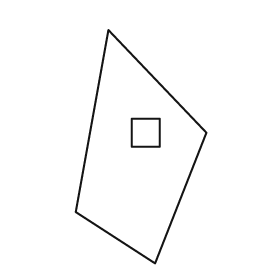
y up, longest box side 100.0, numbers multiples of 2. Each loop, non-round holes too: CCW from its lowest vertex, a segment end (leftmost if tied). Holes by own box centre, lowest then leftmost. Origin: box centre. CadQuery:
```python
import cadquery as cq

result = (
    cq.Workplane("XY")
    .moveTo(6.0, -50.0)
    .lineTo(28.0, 6.0)
    .lineTo(-14.0, 50.0)
    .lineTo(-28.0, -28.0)
    .close()
    .moveTo(-4.0, 0.0)
    .lineTo(8.0, 0.0)
    .lineTo(8.0, 12.0)
    .lineTo(-4.0, 12.0)
    .close()
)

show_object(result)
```